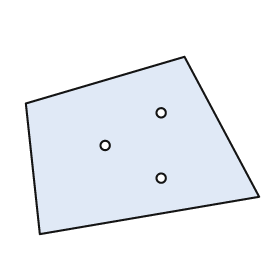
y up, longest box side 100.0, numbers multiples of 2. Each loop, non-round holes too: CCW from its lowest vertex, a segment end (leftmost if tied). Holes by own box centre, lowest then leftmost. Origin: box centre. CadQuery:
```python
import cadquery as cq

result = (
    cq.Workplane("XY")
    .moveTo(-44.0, -38.0)
    .lineTo(50.0, -22.0)
    .lineTo(18.0, 38.0)
    .lineTo(-50.0, 18.0)
    .close()
    .moveTo(8.0, -14.0)
    .circle(2.0)
    .moveTo(-16.0, 0.0)
    .circle(2.0)
    .moveTo(8.0, 14.0)
    .circle(2.0)
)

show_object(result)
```